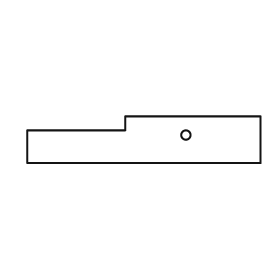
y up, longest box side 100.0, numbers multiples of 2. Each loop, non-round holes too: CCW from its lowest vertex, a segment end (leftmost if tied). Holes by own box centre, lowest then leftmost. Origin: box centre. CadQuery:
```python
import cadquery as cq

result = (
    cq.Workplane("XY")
    .moveTo(-50.0, -10.0)
    .lineTo(50.0, -10.0)
    .lineTo(50.0, 10.0)
    .lineTo(-8.0, 10.0)
    .lineTo(-8.0, 4.0)
    .lineTo(-50.0, 4.0)
    .close()
    .moveTo(18.0, 2.0)
    .circle(2.0)
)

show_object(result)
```